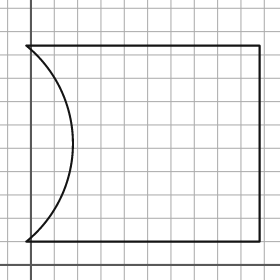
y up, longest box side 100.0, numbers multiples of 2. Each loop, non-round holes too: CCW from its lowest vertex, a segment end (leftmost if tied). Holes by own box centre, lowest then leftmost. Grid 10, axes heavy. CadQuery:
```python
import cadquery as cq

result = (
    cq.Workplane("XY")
    .moveTo(-2.0, 10.0)
    .lineTo(98.0, 10.0)
    .lineTo(98.0, 94.0)
    .lineTo(-2.0, 94.0)
    .threePointArc((18.0, 52.0), (-2.0, 10.0))
    .close()
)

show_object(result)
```